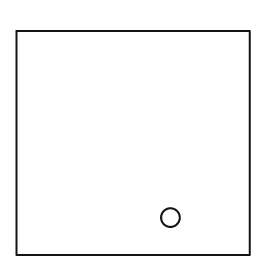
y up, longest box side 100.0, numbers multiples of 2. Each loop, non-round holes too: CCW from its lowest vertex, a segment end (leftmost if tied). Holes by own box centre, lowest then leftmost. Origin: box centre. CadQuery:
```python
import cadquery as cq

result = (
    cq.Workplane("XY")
    .moveTo(-50.0, -48.0)
    .lineTo(50.0, -48.0)
    .lineTo(50.0, 48.0)
    .lineTo(-50.0, 48.0)
    .close()
    .moveTo(16.0, -32.0)
    .circle(4.0)
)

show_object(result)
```